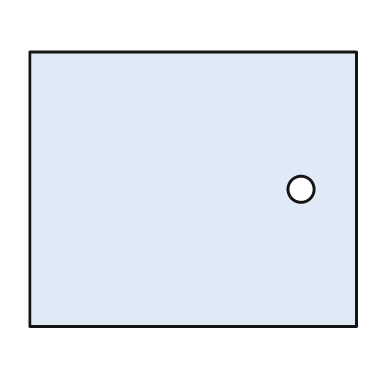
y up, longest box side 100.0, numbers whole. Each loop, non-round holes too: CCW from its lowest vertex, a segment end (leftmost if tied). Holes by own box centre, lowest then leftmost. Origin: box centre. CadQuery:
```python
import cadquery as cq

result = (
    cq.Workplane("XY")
    .moveTo(-50.0, -42.0)
    .lineTo(50.0, -42.0)
    .lineTo(50.0, 42.0)
    .lineTo(-50.0, 42.0)
    .close()
    .moveTo(33.0, 0.0)
    .circle(4.0)
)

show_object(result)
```